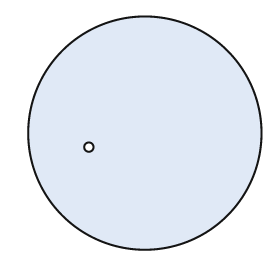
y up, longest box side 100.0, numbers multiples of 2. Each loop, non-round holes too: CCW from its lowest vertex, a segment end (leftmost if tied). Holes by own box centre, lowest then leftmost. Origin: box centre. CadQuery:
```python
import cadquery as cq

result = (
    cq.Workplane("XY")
    .moveTo(0.0, 0.0)
    .circle(50.0)
    .moveTo(-24.0, -6.0)
    .circle(2.0)
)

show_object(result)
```